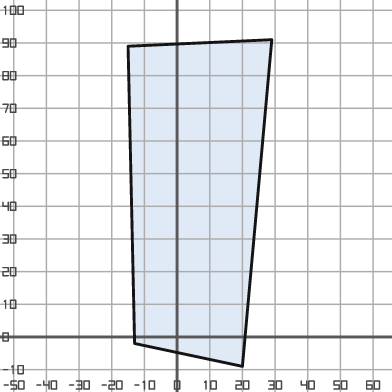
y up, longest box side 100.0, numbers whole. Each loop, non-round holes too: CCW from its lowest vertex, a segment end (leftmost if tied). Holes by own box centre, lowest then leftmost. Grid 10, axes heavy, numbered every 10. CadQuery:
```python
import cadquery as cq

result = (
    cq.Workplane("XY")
    .moveTo(20.0, -9.0)
    .lineTo(29.0, 91.0)
    .lineTo(-15.0, 89.0)
    .lineTo(-13.0, -2.0)
    .close()
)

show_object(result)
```